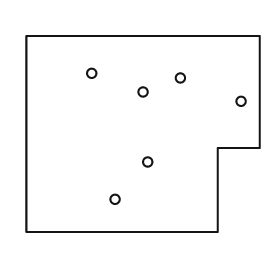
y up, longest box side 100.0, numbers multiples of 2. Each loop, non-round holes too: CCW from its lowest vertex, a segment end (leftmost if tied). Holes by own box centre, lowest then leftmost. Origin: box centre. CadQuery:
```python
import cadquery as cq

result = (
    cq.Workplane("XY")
    .moveTo(-50.0, -42.0)
    .lineTo(32.0, -42.0)
    .lineTo(32.0, -6.0)
    .lineTo(50.0, -6.0)
    .lineTo(50.0, 42.0)
    .lineTo(-50.0, 42.0)
    .close()
    .moveTo(-12.0, -28.0)
    .circle(2.0)
    .moveTo(2.0, -12.0)
    .circle(2.0)
    .moveTo(42.0, 14.0)
    .circle(2.0)
    .moveTo(0.0, 18.0)
    .circle(2.0)
    .moveTo(16.0, 24.0)
    .circle(2.0)
    .moveTo(-22.0, 26.0)
    .circle(2.0)
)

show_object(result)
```